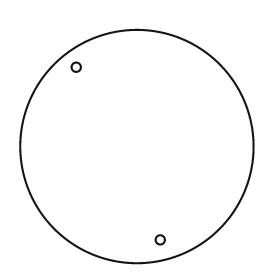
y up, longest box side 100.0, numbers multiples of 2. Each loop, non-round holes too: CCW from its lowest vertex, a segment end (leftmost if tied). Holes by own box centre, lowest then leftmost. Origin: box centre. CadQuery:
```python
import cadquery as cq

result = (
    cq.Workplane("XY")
    .moveTo(0.0, 0.0)
    .circle(50.0)
    .moveTo(10.0, -40.0)
    .circle(2.0)
    .moveTo(-26.0, 34.0)
    .circle(2.0)
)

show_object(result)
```